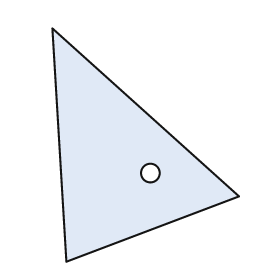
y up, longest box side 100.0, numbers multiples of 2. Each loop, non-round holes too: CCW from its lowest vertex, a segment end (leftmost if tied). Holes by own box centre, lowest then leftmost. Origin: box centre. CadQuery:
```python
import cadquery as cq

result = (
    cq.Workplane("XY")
    .moveTo(-34.0, -50.0)
    .lineTo(40.0, -22.0)
    .lineTo(-40.0, 50.0)
    .close()
    .moveTo(2.0, -12.0)
    .circle(4.0)
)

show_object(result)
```